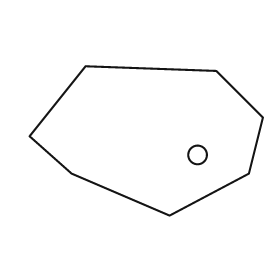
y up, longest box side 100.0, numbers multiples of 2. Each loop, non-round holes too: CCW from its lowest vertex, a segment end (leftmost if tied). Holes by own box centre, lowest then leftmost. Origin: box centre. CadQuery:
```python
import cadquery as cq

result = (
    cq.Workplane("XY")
    .moveTo(10.0, -32.0)
    .lineTo(44.0, -14.0)
    .lineTo(50.0, 10.0)
    .lineTo(30.0, 30.0)
    .lineTo(-26.0, 32.0)
    .lineTo(-50.0, 2.0)
    .lineTo(-32.0, -14.0)
    .close()
    .moveTo(22.0, -6.0)
    .circle(4.0)
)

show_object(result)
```